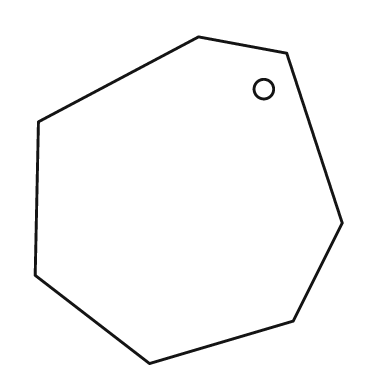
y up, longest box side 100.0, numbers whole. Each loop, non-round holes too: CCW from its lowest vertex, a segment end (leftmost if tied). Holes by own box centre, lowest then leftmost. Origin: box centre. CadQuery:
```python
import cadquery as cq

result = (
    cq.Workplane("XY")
    .moveTo(-12.0, -50.0)
    .lineTo(32.0, -37.0)
    .lineTo(47.0, -7.0)
    .lineTo(30.0, 45.0)
    .lineTo(3.0, 50.0)
    .lineTo(-46.0, 24.0)
    .lineTo(-47.0, -23.0)
    .close()
    .moveTo(23.0, 34.0)
    .circle(3.0)
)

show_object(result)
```